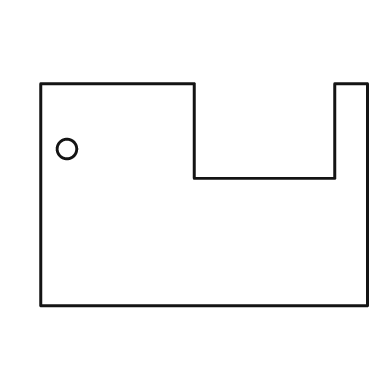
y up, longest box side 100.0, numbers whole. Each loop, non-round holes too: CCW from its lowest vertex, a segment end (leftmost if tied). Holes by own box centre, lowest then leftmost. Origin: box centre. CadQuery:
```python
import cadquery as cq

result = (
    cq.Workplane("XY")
    .moveTo(-50.0, -34.0)
    .lineTo(50.0, -34.0)
    .lineTo(50.0, 34.0)
    .lineTo(40.0, 34.0)
    .lineTo(40.0, 5.0)
    .lineTo(-3.0, 5.0)
    .lineTo(-3.0, 34.0)
    .lineTo(-50.0, 34.0)
    .close()
    .moveTo(-42.0, 14.0)
    .circle(3.0)
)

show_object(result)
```